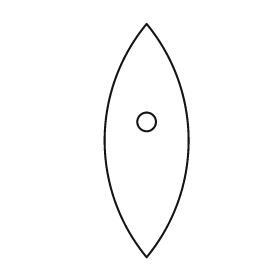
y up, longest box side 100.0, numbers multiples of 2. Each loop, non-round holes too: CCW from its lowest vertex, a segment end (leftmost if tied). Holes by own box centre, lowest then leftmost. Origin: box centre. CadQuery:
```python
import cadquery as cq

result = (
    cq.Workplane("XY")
    .moveTo(0.0, -50.0)
    .threePointArc((18.0, 0.0), (0.0, 50.0))
    .threePointArc((-18.0, 0.0), (0.0, -50.0))
    .close()
    .moveTo(0.0, 8.0)
    .circle(4.0)
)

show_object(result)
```